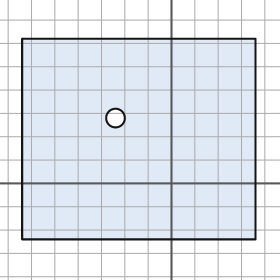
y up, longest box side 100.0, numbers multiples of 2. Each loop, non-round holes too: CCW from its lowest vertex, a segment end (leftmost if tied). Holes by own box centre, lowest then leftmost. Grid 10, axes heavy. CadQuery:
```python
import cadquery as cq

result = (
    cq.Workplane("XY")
    .moveTo(-64.0, -24.0)
    .lineTo(36.0, -24.0)
    .lineTo(36.0, 62.0)
    .lineTo(-64.0, 62.0)
    .close()
    .moveTo(-24.0, 28.0)
    .circle(4.0)
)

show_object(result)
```